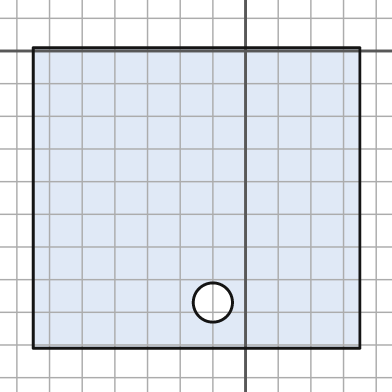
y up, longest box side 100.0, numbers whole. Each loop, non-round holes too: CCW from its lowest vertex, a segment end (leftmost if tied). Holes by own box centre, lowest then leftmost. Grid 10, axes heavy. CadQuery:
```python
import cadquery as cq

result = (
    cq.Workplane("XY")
    .moveTo(-65.0, -91.0)
    .lineTo(35.0, -91.0)
    .lineTo(35.0, 1.0)
    .lineTo(-65.0, 1.0)
    .close()
    .moveTo(-10.0, -77.0)
    .circle(6.0)
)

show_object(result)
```